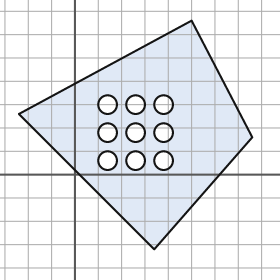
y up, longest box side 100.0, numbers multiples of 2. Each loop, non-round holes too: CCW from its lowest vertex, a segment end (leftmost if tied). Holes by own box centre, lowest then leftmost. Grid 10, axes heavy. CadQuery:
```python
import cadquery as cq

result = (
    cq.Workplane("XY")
    .moveTo(34.0, -32.0)
    .lineTo(76.0, 16.0)
    .lineTo(50.0, 66.0)
    .lineTo(-24.0, 26.0)
    .close()
    .moveTo(14.0, 6.0)
    .circle(4.0)
    .moveTo(26.0, 6.0)
    .circle(4.0)
    .moveTo(38.0, 6.0)
    .circle(4.0)
    .moveTo(14.0, 18.0)
    .circle(4.0)
    .moveTo(26.0, 18.0)
    .circle(4.0)
    .moveTo(38.0, 18.0)
    .circle(4.0)
    .moveTo(14.0, 30.0)
    .circle(4.0)
    .moveTo(26.0, 30.0)
    .circle(4.0)
    .moveTo(38.0, 30.0)
    .circle(4.0)
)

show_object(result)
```